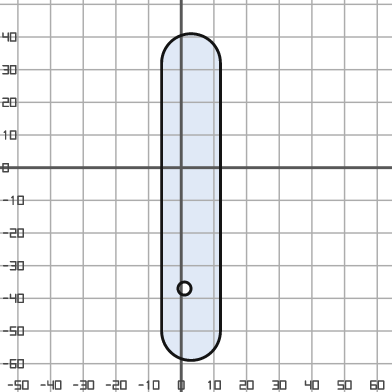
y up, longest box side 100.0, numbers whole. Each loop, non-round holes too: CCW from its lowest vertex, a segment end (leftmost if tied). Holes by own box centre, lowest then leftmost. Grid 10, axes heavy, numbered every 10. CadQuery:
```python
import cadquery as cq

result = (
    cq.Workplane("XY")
    .moveTo(-6.0, -50.0)
    .threePointArc((3.0, -59.0), (12.0, -50.0))
    .lineTo(12.0, 32.0)
    .threePointArc((3.0, 41.0), (-6.0, 32.0))
    .close()
    .moveTo(1.0, -37.0)
    .circle(2.0)
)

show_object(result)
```